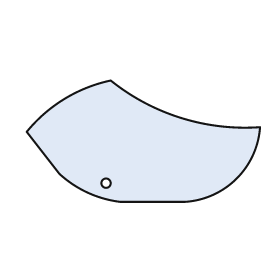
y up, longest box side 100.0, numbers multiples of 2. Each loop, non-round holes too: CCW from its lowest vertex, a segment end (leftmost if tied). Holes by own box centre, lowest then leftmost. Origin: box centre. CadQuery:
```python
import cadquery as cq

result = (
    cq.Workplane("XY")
    .moveTo(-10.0, -26.0)
    .lineTo(18.0, -26.0)
    .threePointArc((40.0, -16.0), (50.0, 6.0))
    .threePointArc((16.0, 10.0), (-14.0, 26.0))
    .threePointArc((-34.0, 18.0), (-50.0, 4.0))
    .lineTo(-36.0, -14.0)
    .threePointArc((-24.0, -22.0), (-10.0, -26.0))
    .close()
    .moveTo(-16.0, -18.0)
    .circle(2.0)
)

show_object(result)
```